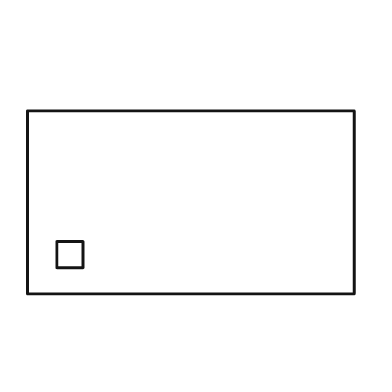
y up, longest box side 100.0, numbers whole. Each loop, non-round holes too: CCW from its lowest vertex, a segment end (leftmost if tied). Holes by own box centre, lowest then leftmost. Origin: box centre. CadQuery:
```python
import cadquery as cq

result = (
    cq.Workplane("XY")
    .moveTo(-50.0, -28.0)
    .lineTo(50.0, -28.0)
    .lineTo(50.0, 28.0)
    .lineTo(-50.0, 28.0)
    .close()
    .moveTo(-41.0, -20.0)
    .lineTo(-33.0, -20.0)
    .lineTo(-33.0, -12.0)
    .lineTo(-41.0, -12.0)
    .close()
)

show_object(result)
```